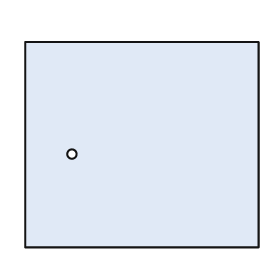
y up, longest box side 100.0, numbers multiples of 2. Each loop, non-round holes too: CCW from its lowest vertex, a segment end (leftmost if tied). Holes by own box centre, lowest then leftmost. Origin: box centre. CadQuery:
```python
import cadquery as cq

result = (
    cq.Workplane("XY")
    .moveTo(-50.0, -44.0)
    .lineTo(50.0, -44.0)
    .lineTo(50.0, 44.0)
    .lineTo(-50.0, 44.0)
    .close()
    .moveTo(-30.0, -4.0)
    .circle(2.0)
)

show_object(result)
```